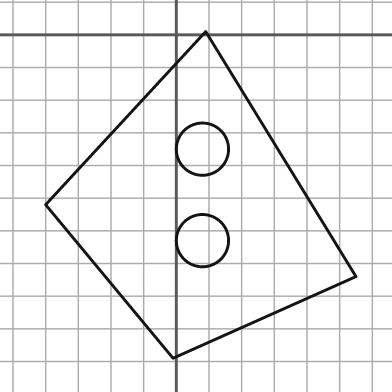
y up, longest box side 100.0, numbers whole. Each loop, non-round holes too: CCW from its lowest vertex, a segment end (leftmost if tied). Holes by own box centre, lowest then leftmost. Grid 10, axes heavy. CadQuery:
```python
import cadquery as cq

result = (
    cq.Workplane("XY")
    .moveTo(-1.0, -99.0)
    .lineTo(55.0, -74.0)
    .lineTo(9.0, 1.0)
    .lineTo(-40.0, -52.0)
    .close()
    .moveTo(8.0, -63.0)
    .circle(8.0)
    .moveTo(8.0, -35.0)
    .circle(8.0)
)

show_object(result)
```